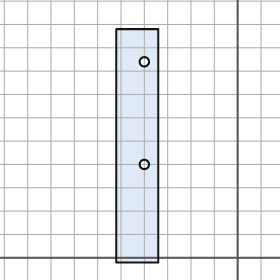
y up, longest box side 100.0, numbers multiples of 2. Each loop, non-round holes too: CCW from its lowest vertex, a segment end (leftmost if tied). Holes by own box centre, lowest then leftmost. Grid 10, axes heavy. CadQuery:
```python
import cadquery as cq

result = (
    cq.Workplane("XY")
    .moveTo(-52.0, -2.0)
    .lineTo(-34.0, -2.0)
    .lineTo(-34.0, 98.0)
    .lineTo(-52.0, 98.0)
    .close()
    .moveTo(-40.0, 40.0)
    .circle(2.0)
    .moveTo(-40.0, 84.0)
    .circle(2.0)
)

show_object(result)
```